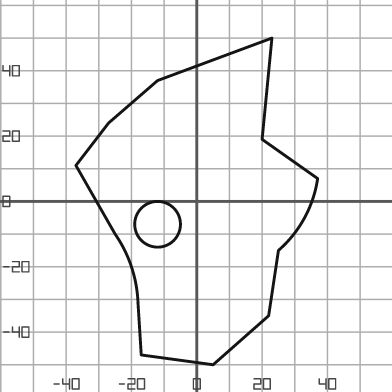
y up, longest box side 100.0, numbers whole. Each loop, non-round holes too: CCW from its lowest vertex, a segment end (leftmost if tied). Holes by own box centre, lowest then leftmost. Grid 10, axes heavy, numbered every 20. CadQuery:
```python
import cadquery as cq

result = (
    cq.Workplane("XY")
    .moveTo(5.0, -50.0)
    .lineTo(22.0, -35.0)
    .lineTo(25.0, -15.0)
    .threePointArc((33.0, -5.0), (37.0, 7.0))
    .lineTo(20.0, 19.0)
    .lineTo(23.0, 50.0)
    .lineTo(-12.0, 37.0)
    .lineTo(-27.0, 24.0)
    .lineTo(-37.0, 11.0)
    .lineTo(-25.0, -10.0)
    .threePointArc((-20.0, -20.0), (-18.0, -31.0))
    .lineTo(-17.0, -47.0)
    .close()
    .moveTo(-12.0, -7.0)
    .circle(7.0)
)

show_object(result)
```